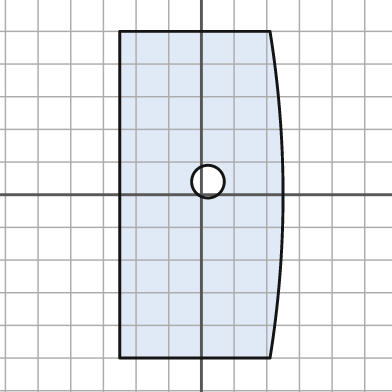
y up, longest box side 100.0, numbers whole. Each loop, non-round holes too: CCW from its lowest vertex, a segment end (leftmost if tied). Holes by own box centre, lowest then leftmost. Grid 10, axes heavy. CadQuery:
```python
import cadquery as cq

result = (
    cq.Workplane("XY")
    .moveTo(-25.0, -50.0)
    .lineTo(21.0, -50.0)
    .threePointArc((25.0, 0.0), (21.0, 50.0))
    .lineTo(-25.0, 50.0)
    .close()
    .moveTo(2.0, 4.0)
    .circle(5.0)
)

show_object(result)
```